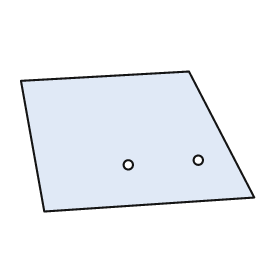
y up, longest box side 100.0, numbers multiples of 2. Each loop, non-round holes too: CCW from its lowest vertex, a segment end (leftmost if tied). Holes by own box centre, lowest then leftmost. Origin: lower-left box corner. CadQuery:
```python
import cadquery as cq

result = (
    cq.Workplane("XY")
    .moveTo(10.0, 0.0)
    .lineTo(100.0, 6.0)
    .lineTo(72.0, 60.0)
    .lineTo(0.0, 56.0)
    .close()
    .moveTo(46.0, 20.0)
    .circle(2.0)
    .moveTo(76.0, 22.0)
    .circle(2.0)
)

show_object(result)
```